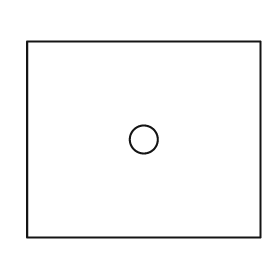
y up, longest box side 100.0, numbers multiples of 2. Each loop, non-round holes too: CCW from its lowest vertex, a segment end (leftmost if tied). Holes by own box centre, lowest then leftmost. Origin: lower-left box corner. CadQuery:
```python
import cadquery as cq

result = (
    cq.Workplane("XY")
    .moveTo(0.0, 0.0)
    .lineTo(100.0, 0.0)
    .lineTo(100.0, 84.0)
    .lineTo(0.0, 84.0)
    .close()
    .moveTo(50.0, 42.0)
    .circle(6.0)
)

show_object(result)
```